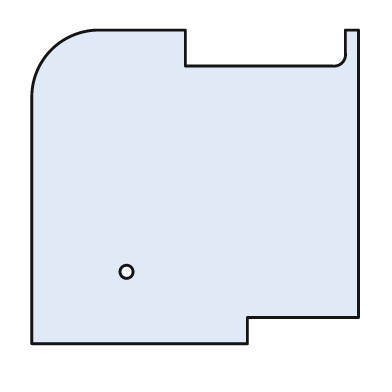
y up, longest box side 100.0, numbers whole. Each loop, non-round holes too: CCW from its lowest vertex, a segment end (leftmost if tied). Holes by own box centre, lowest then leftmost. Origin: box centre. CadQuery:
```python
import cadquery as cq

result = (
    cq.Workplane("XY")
    .moveTo(-50.0, -48.0)
    .lineTo(16.0, -48.0)
    .lineTo(16.0, -40.0)
    .lineTo(50.0, -40.0)
    .lineTo(50.0, 48.0)
    .lineTo(46.0, 48.0)
    .lineTo(46.0, 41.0)
    .threePointArc((45.0, 38.0), (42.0, 37.0))
    .lineTo(-3.0, 37.0)
    .lineTo(-3.0, 48.0)
    .lineTo(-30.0, 48.0)
    .threePointArc((-44.0, 42.0), (-50.0, 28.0))
    .close()
    .moveTo(-21.0, -26.0)
    .circle(2.0)
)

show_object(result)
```